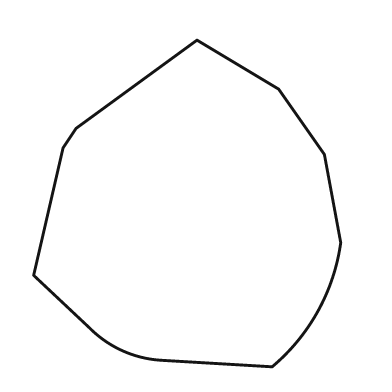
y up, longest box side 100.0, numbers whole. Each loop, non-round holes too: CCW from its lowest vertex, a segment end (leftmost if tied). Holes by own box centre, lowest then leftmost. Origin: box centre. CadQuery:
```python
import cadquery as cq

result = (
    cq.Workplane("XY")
    .moveTo(26.0, -50.0)
    .threePointArc((40.0, -33.0), (47.0, -12.0))
    .lineTo(42.0, 15.0)
    .lineTo(28.0, 35.0)
    .lineTo(3.0, 50.0)
    .lineTo(-34.0, 23.0)
    .lineTo(-38.0, 17.0)
    .lineTo(-47.0, -22.0)
    .lineTo(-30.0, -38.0)
    .threePointArc((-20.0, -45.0), (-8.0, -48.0))
    .close()
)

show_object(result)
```